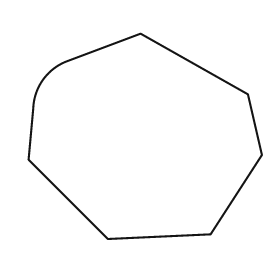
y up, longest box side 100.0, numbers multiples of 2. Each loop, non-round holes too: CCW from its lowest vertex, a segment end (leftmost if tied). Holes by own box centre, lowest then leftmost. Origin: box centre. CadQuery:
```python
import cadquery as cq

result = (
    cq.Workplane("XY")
    .moveTo(-16.0, -44.0)
    .lineTo(28.0, -42.0)
    .lineTo(50.0, -8.0)
    .lineTo(44.0, 18.0)
    .lineTo(-2.0, 44.0)
    .lineTo(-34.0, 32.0)
    .threePointArc((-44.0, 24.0), (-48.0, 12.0))
    .lineTo(-50.0, -10.0)
    .close()
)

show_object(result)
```